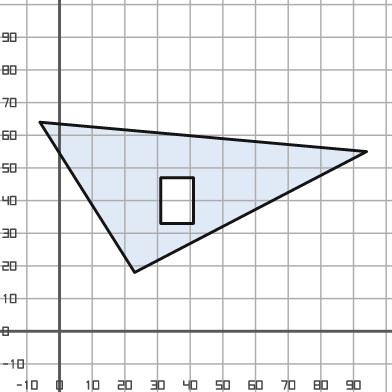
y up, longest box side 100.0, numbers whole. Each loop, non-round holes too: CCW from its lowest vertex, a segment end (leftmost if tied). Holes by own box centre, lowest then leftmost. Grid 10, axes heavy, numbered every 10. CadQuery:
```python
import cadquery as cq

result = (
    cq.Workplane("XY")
    .moveTo(23.0, 18.0)
    .lineTo(94.0, 55.0)
    .lineTo(-6.0, 64.0)
    .close()
    .moveTo(31.0, 33.0)
    .lineTo(41.0, 33.0)
    .lineTo(41.0, 47.0)
    .lineTo(31.0, 47.0)
    .close()
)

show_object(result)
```